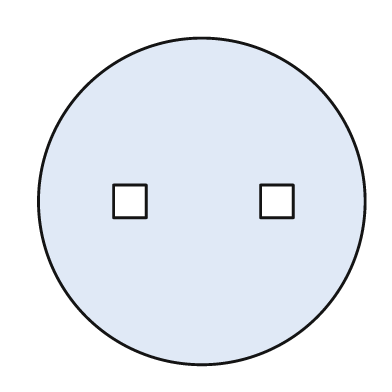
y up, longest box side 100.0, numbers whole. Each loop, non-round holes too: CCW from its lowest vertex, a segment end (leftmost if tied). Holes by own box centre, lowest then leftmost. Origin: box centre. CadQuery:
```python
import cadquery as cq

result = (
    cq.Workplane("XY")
    .moveTo(0.0, 0.0)
    .circle(50.0)
    .moveTo(-27.0, -5.0)
    .lineTo(-17.0, -5.0)
    .lineTo(-17.0, 5.0)
    .lineTo(-27.0, 5.0)
    .close()
    .moveTo(18.0, -5.0)
    .lineTo(28.0, -5.0)
    .lineTo(28.0, 5.0)
    .lineTo(18.0, 5.0)
    .close()
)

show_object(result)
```